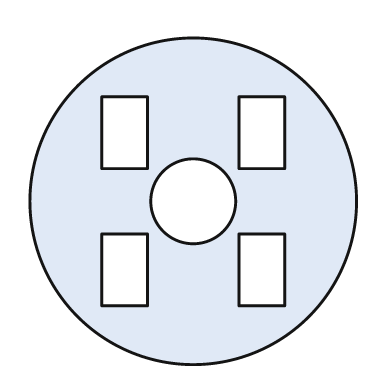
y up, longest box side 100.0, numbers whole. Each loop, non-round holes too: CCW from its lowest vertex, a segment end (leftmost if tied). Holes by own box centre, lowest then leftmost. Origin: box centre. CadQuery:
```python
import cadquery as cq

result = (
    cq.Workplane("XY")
    .moveTo(0.0, 0.0)
    .circle(50.0)
    .moveTo(-28.0, -32.0)
    .lineTo(-14.0, -32.0)
    .lineTo(-14.0, -10.0)
    .lineTo(-28.0, -10.0)
    .close()
    .moveTo(14.0, -32.0)
    .lineTo(28.0, -32.0)
    .lineTo(28.0, -10.0)
    .lineTo(14.0, -10.0)
    .close()
    .moveTo(0.0, 0.0)
    .circle(13.0)
    .moveTo(-28.0, 10.0)
    .lineTo(-14.0, 10.0)
    .lineTo(-14.0, 32.0)
    .lineTo(-28.0, 32.0)
    .close()
    .moveTo(14.0, 10.0)
    .lineTo(28.0, 10.0)
    .lineTo(28.0, 32.0)
    .lineTo(14.0, 32.0)
    .close()
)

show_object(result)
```